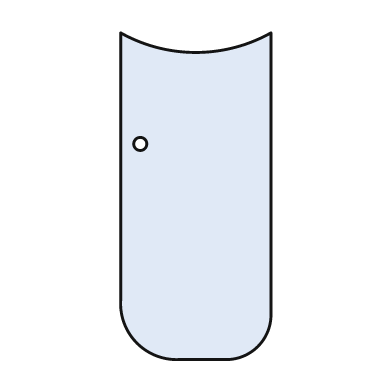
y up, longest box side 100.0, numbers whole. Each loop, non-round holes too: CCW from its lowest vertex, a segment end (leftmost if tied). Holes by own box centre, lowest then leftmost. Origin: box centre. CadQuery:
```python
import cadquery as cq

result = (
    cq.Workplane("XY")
    .moveTo(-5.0, -50.0)
    .lineTo(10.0, -50.0)
    .threePointArc((19.0, -46.0), (23.0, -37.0))
    .lineTo(23.0, 50.0)
    .threePointArc((0.0, 44.0), (-23.0, 50.0))
    .lineTo(-23.0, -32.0)
    .threePointArc((-18.0, -45.0), (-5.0, -50.0))
    .close()
    .moveTo(-17.0, 16.0)
    .circle(2.0)
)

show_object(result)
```